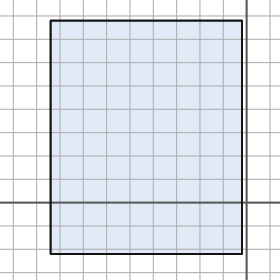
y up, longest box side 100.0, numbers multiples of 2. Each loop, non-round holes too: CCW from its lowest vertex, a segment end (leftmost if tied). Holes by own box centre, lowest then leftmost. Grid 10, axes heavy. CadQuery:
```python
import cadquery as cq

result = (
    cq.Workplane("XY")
    .moveTo(-84.0, -22.0)
    .lineTo(-2.0, -22.0)
    .lineTo(-2.0, 78.0)
    .lineTo(-84.0, 78.0)
    .close()
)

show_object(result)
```